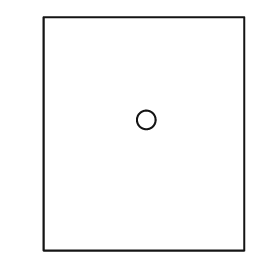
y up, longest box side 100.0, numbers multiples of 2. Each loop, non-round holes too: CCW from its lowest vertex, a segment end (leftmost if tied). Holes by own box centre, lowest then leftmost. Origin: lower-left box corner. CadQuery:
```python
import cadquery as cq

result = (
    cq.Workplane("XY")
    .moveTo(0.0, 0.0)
    .lineTo(86.0, 0.0)
    .lineTo(86.0, 100.0)
    .lineTo(0.0, 100.0)
    .close()
    .moveTo(44.0, 56.0)
    .circle(4.0)
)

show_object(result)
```